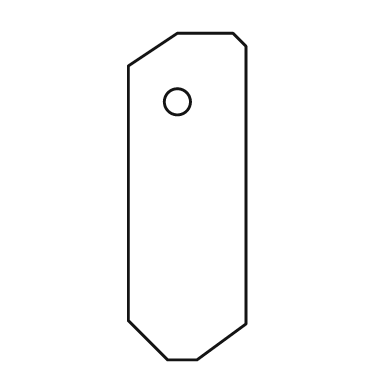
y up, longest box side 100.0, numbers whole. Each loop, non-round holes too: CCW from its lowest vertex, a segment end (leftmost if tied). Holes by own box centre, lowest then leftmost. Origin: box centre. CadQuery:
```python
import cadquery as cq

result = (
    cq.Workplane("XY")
    .moveTo(-6.0, -50.0)
    .lineTo(3.0, -50.0)
    .lineTo(18.0, -39.0)
    .lineTo(18.0, 46.0)
    .lineTo(14.0, 50.0)
    .lineTo(-3.0, 50.0)
    .lineTo(-18.0, 40.0)
    .lineTo(-18.0, -38.0)
    .close()
    .moveTo(-3.0, 29.0)
    .circle(4.0)
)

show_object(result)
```